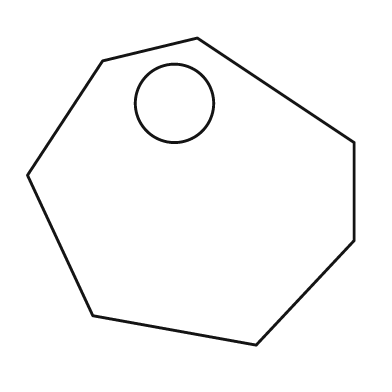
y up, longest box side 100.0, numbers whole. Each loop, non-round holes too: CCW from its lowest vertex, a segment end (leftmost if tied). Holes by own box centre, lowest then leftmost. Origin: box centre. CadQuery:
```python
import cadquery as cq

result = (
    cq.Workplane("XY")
    .moveTo(20.0, -47.0)
    .lineTo(50.0, -15.0)
    .lineTo(50.0, 15.0)
    .lineTo(2.0, 47.0)
    .lineTo(-27.0, 40.0)
    .lineTo(-50.0, 5.0)
    .lineTo(-30.0, -38.0)
    .close()
    .moveTo(-5.0, 27.0)
    .circle(12.0)
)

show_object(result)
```